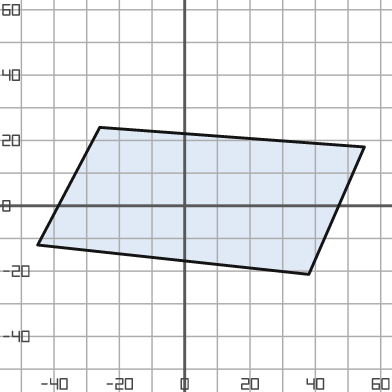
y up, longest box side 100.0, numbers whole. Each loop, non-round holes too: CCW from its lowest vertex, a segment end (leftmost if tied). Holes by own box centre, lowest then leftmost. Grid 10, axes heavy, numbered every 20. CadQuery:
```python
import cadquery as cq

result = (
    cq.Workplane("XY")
    .moveTo(38.0, -21.0)
    .lineTo(55.0, 18.0)
    .lineTo(-26.0, 24.0)
    .lineTo(-45.0, -12.0)
    .close()
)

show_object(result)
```